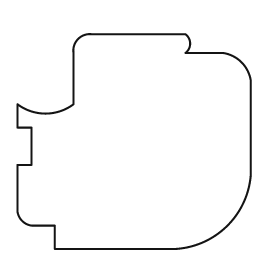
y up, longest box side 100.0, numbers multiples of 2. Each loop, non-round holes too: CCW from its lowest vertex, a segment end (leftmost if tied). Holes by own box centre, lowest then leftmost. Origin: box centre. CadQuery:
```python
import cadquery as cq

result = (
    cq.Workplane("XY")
    .moveTo(-34.0, -46.0)
    .lineTo(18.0, -46.0)
    .threePointArc((40.0, -36.0), (50.0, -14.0))
    .lineTo(50.0, 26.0)
    .threePointArc((46.0, 34.0), (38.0, 38.0))
    .lineTo(22.0, 38.0)
    .threePointArc((24.0, 42.0), (22.0, 46.0))
    .lineTo(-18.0, 46.0)
    .threePointArc((-24.0, 44.0), (-26.0, 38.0))
    .lineTo(-26.0, 16.0)
    .threePointArc((-38.0, 12.0), (-50.0, 16.0))
    .lineTo(-50.0, 6.0)
    .lineTo(-44.0, 6.0)
    .lineTo(-44.0, -10.0)
    .lineTo(-50.0, -10.0)
    .lineTo(-50.0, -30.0)
    .threePointArc((-48.0, -34.0), (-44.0, -36.0))
    .lineTo(-34.0, -36.0)
    .close()
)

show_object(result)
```